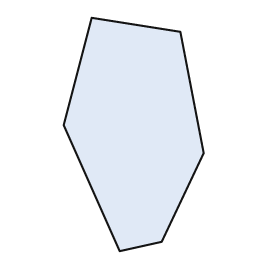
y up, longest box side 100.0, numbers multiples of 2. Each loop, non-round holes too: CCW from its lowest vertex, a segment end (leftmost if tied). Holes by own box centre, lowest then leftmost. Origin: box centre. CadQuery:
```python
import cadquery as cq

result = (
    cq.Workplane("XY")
    .moveTo(-6.0, -50.0)
    .lineTo(12.0, -46.0)
    .lineTo(30.0, -8.0)
    .lineTo(20.0, 44.0)
    .lineTo(-18.0, 50.0)
    .lineTo(-30.0, 4.0)
    .close()
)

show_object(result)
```